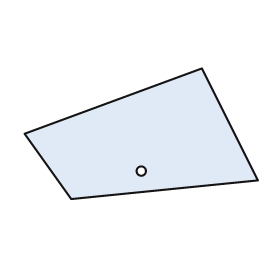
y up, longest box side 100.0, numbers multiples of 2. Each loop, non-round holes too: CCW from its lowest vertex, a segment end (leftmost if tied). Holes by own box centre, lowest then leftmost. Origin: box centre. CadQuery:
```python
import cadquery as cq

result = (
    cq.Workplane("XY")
    .moveTo(-30.0, -28.0)
    .lineTo(50.0, -20.0)
    .lineTo(26.0, 28.0)
    .lineTo(-50.0, 0.0)
    .close()
    .moveTo(0.0, -16.0)
    .circle(2.0)
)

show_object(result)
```